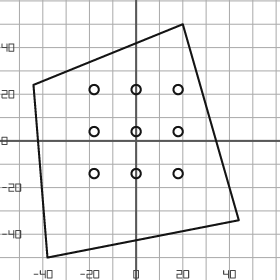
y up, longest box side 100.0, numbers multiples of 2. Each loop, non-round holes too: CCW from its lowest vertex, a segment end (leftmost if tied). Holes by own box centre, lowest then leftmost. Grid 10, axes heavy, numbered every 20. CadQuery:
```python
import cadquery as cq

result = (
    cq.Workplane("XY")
    .moveTo(-38.0, -50.0)
    .lineTo(44.0, -34.0)
    .lineTo(20.0, 50.0)
    .lineTo(-44.0, 24.0)
    .close()
    .moveTo(-18.0, -14.0)
    .circle(2.0)
    .moveTo(0.0, -14.0)
    .circle(2.0)
    .moveTo(18.0, -14.0)
    .circle(2.0)
    .moveTo(-18.0, 4.0)
    .circle(2.0)
    .moveTo(0.0, 4.0)
    .circle(2.0)
    .moveTo(18.0, 4.0)
    .circle(2.0)
    .moveTo(-18.0, 22.0)
    .circle(2.0)
    .moveTo(0.0, 22.0)
    .circle(2.0)
    .moveTo(18.0, 22.0)
    .circle(2.0)
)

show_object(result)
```